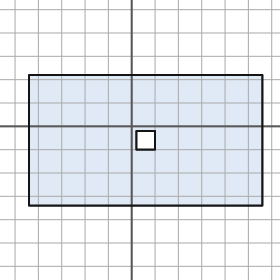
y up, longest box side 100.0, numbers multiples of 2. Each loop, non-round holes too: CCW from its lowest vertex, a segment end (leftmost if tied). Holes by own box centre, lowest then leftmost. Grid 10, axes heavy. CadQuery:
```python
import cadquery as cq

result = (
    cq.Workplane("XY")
    .moveTo(-44.0, -34.0)
    .lineTo(56.0, -34.0)
    .lineTo(56.0, 22.0)
    .lineTo(-44.0, 22.0)
    .close()
    .moveTo(2.0, -10.0)
    .lineTo(10.0, -10.0)
    .lineTo(10.0, -2.0)
    .lineTo(2.0, -2.0)
    .close()
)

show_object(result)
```